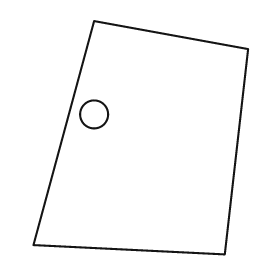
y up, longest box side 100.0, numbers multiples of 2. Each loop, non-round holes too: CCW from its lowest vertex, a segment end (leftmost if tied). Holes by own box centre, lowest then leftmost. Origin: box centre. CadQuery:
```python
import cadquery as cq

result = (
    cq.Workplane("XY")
    .moveTo(36.0, -50.0)
    .lineTo(46.0, 38.0)
    .lineTo(-20.0, 50.0)
    .lineTo(-46.0, -46.0)
    .close()
    .moveTo(-20.0, 10.0)
    .circle(6.0)
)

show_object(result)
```